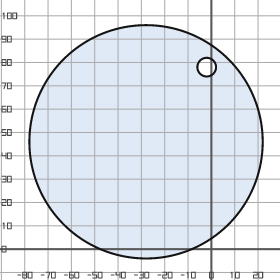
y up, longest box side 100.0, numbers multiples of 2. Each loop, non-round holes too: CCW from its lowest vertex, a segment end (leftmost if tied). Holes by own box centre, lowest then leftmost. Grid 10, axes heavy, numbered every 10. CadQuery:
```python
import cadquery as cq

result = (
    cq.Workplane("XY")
    .moveTo(-28.0, 46.0)
    .circle(50.0)
    .moveTo(-2.0, 78.0)
    .circle(4.0)
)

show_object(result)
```